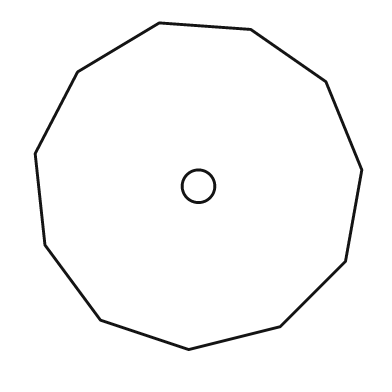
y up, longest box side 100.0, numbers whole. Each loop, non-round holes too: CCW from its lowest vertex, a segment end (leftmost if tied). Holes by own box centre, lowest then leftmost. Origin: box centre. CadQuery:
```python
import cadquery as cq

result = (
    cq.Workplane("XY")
    .moveTo(-3.0, -50.0)
    .lineTo(25.0, -43.0)
    .lineTo(45.0, -23.0)
    .lineTo(50.0, 5.0)
    .lineTo(39.0, 32.0)
    .lineTo(16.0, 48.0)
    .lineTo(-12.0, 50.0)
    .lineTo(-37.0, 35.0)
    .lineTo(-50.0, 10.0)
    .lineTo(-47.0, -18.0)
    .lineTo(-30.0, -41.0)
    .close()
    .moveTo(0.0, 0.0)
    .circle(5.0)
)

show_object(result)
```